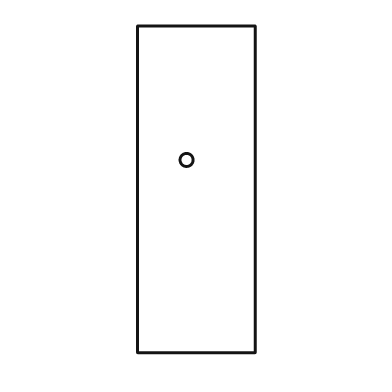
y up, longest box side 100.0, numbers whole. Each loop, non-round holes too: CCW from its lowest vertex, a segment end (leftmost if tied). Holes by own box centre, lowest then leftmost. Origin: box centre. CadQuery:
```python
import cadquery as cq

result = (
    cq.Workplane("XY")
    .moveTo(-18.0, -50.0)
    .lineTo(18.0, -50.0)
    .lineTo(18.0, 50.0)
    .lineTo(-18.0, 50.0)
    .close()
    .moveTo(-3.0, 9.0)
    .circle(2.0)
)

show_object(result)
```